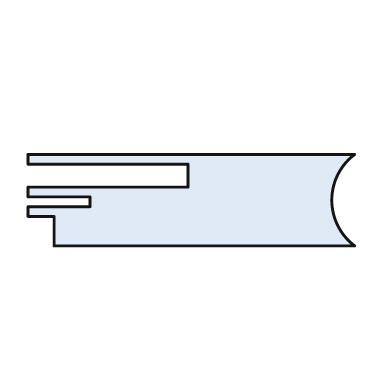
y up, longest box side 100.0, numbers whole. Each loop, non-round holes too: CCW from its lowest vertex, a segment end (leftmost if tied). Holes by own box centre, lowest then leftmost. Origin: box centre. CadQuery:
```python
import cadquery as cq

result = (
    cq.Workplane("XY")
    .moveTo(-42.0, -14.0)
    .lineTo(50.0, -14.0)
    .threePointArc((43.0, 0.0), (50.0, 14.0))
    .lineTo(-50.0, 14.0)
    .lineTo(-50.0, 11.0)
    .lineTo(-1.0, 11.0)
    .lineTo(-1.0, 4.0)
    .lineTo(-50.0, 4.0)
    .lineTo(-50.0, 1.0)
    .lineTo(-31.0, 1.0)
    .lineTo(-31.0, -2.0)
    .lineTo(-50.0, -2.0)
    .lineTo(-50.0, -5.0)
    .lineTo(-42.0, -5.0)
    .close()
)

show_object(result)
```